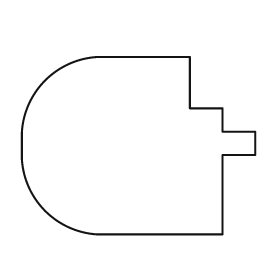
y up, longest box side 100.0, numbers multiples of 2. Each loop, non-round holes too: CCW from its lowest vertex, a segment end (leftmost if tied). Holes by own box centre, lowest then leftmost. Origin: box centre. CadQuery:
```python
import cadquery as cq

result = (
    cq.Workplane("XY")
    .moveTo(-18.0, -38.0)
    .lineTo(36.0, -38.0)
    .lineTo(36.0, -4.0)
    .lineTo(50.0, -4.0)
    .lineTo(50.0, 6.0)
    .lineTo(36.0, 6.0)
    .lineTo(36.0, 16.0)
    .lineTo(22.0, 16.0)
    .lineTo(22.0, 38.0)
    .lineTo(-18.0, 38.0)
    .threePointArc((-40.0, 28.0), (-50.0, 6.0))
    .lineTo(-50.0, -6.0)
    .threePointArc((-40.0, -28.0), (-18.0, -38.0))
    .close()
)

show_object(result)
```